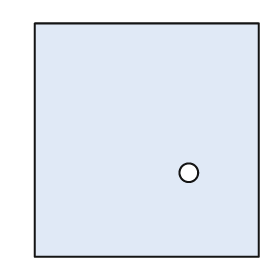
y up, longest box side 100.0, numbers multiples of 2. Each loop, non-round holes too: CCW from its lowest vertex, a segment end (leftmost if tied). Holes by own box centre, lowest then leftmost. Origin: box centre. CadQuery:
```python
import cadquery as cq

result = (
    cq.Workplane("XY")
    .moveTo(-48.0, -50.0)
    .lineTo(48.0, -50.0)
    .lineTo(48.0, 50.0)
    .lineTo(-48.0, 50.0)
    .close()
    .moveTo(18.0, -14.0)
    .circle(4.0)
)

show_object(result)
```